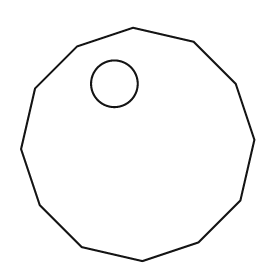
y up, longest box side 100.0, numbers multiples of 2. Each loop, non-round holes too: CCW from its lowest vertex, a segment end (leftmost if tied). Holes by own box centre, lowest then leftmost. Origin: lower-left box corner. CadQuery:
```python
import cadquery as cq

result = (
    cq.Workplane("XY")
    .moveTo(52.0, 0.0)
    .lineTo(76.0, 8.0)
    .lineTo(94.0, 26.0)
    .lineTo(100.0, 52.0)
    .lineTo(92.0, 76.0)
    .lineTo(74.0, 94.0)
    .lineTo(48.0, 100.0)
    .lineTo(24.0, 92.0)
    .lineTo(6.0, 74.0)
    .lineTo(0.0, 48.0)
    .lineTo(8.0, 24.0)
    .lineTo(26.0, 6.0)
    .close()
    .moveTo(40.0, 76.0)
    .circle(10.0)
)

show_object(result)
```